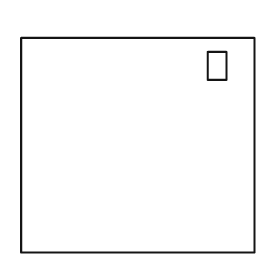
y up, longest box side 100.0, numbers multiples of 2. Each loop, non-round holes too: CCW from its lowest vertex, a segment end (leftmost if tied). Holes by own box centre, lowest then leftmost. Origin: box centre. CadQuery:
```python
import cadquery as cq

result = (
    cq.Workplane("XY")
    .moveTo(-50.0, -46.0)
    .lineTo(50.0, -46.0)
    .lineTo(50.0, 46.0)
    .lineTo(-50.0, 46.0)
    .close()
    .moveTo(30.0, 28.0)
    .lineTo(38.0, 28.0)
    .lineTo(38.0, 40.0)
    .lineTo(30.0, 40.0)
    .close()
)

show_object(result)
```